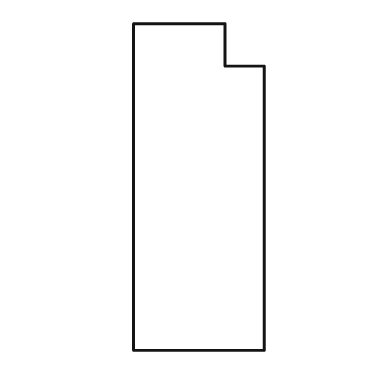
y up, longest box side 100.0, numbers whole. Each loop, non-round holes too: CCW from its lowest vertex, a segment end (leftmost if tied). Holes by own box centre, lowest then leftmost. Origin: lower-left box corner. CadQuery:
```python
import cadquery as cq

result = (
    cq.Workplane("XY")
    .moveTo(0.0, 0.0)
    .lineTo(40.0, 0.0)
    .lineTo(40.0, 87.0)
    .lineTo(28.0, 87.0)
    .lineTo(28.0, 100.0)
    .lineTo(0.0, 100.0)
    .close()
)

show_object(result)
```